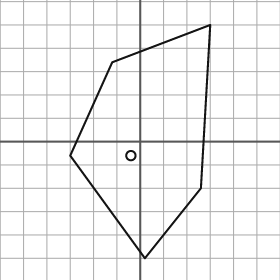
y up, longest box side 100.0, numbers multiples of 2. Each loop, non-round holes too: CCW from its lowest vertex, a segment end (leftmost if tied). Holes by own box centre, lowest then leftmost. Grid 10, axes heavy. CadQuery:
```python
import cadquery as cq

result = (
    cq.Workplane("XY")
    .moveTo(2.0, -50.0)
    .lineTo(26.0, -20.0)
    .lineTo(30.0, 50.0)
    .lineTo(-12.0, 34.0)
    .lineTo(-30.0, -6.0)
    .close()
    .moveTo(-4.0, -6.0)
    .circle(2.0)
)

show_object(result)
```